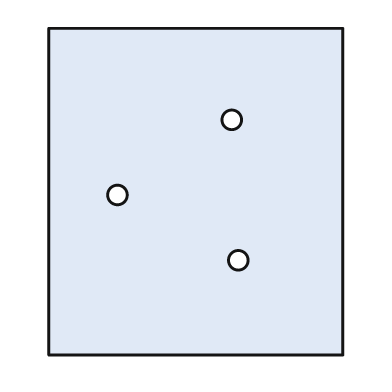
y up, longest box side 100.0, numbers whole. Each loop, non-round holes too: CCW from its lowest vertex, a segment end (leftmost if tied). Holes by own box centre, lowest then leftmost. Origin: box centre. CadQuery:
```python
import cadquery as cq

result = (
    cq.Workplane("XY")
    .moveTo(-45.0, -50.0)
    .lineTo(45.0, -50.0)
    .lineTo(45.0, 50.0)
    .lineTo(-45.0, 50.0)
    .close()
    .moveTo(13.0, -21.0)
    .circle(3.0)
    .moveTo(-24.0, -1.0)
    .circle(3.0)
    .moveTo(11.0, 22.0)
    .circle(3.0)
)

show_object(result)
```